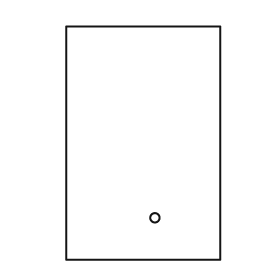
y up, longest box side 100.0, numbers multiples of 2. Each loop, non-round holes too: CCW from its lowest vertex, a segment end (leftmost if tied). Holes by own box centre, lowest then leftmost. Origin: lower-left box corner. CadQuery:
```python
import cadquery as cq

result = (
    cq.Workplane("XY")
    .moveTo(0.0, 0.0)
    .lineTo(66.0, 0.0)
    .lineTo(66.0, 100.0)
    .lineTo(0.0, 100.0)
    .close()
    .moveTo(38.0, 18.0)
    .circle(2.0)
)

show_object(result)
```